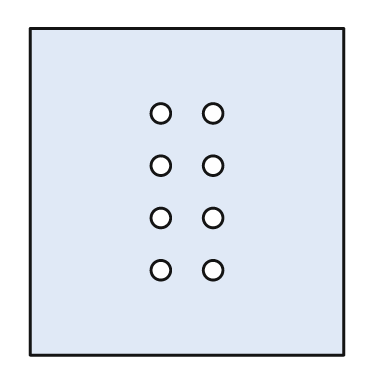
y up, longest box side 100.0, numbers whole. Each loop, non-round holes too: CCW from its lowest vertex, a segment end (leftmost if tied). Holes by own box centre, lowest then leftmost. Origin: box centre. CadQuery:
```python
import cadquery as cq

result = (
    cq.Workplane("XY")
    .moveTo(-48.0, -50.0)
    .lineTo(48.0, -50.0)
    .lineTo(48.0, 50.0)
    .lineTo(-48.0, 50.0)
    .close()
    .moveTo(-8.0, -24.0)
    .circle(3.0)
    .moveTo(8.0, -24.0)
    .circle(3.0)
    .moveTo(-8.0, -8.0)
    .circle(3.0)
    .moveTo(8.0, -8.0)
    .circle(3.0)
    .moveTo(-8.0, 8.0)
    .circle(3.0)
    .moveTo(8.0, 8.0)
    .circle(3.0)
    .moveTo(-8.0, 24.0)
    .circle(3.0)
    .moveTo(8.0, 24.0)
    .circle(3.0)
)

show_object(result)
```